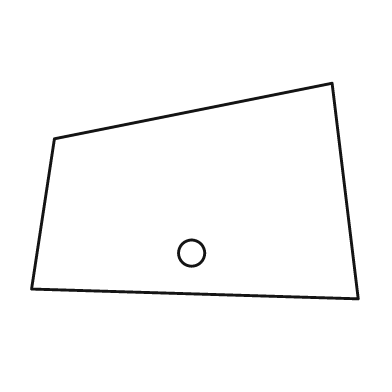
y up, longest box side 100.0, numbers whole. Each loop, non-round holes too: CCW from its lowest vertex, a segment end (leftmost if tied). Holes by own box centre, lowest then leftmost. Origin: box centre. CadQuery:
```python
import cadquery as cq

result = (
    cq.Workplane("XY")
    .moveTo(50.0, -33.0)
    .lineTo(42.0, 33.0)
    .lineTo(-43.0, 16.0)
    .lineTo(-50.0, -30.0)
    .close()
    .moveTo(-1.0, -19.0)
    .circle(4.0)
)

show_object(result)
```